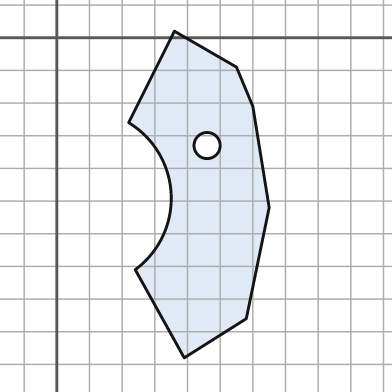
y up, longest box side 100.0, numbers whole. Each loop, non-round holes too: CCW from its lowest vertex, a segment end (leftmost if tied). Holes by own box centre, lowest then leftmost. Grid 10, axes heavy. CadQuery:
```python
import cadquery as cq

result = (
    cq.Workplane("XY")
    .moveTo(39.0, -98.0)
    .lineTo(58.0, -86.0)
    .lineTo(65.0, -52.0)
    .lineTo(60.0, -21.0)
    .lineTo(55.0, -9.0)
    .lineTo(36.0, 2.0)
    .lineTo(22.0, -26.0)
    .threePointArc((35.0, -48.0), (24.0, -71.0))
    .close()
    .moveTo(46.0, -33.0)
    .circle(4.0)
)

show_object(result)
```